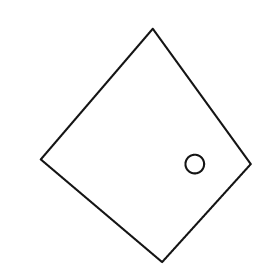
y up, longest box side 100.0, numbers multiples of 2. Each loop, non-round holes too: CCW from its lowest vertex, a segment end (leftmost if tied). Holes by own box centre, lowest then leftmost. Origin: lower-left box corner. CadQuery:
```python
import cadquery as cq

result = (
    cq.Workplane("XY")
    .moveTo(52.0, 0.0)
    .lineTo(90.0, 42.0)
    .lineTo(48.0, 100.0)
    .lineTo(0.0, 44.0)
    .close()
    .moveTo(66.0, 42.0)
    .circle(4.0)
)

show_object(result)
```